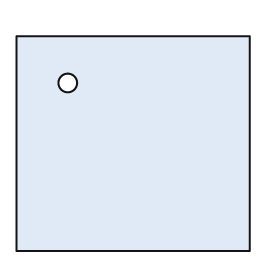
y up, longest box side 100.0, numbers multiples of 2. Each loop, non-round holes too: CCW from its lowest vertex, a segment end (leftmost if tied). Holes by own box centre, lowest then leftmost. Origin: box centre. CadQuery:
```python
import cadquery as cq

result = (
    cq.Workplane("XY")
    .moveTo(-50.0, -46.0)
    .lineTo(50.0, -46.0)
    .lineTo(50.0, 46.0)
    .lineTo(-50.0, 46.0)
    .close()
    .moveTo(-28.0, 26.0)
    .circle(4.0)
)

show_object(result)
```